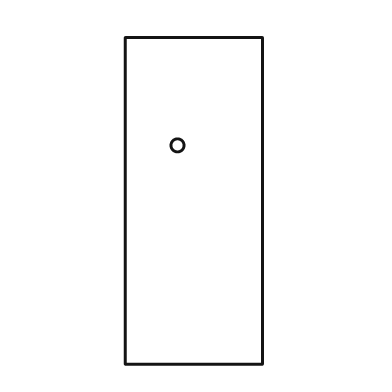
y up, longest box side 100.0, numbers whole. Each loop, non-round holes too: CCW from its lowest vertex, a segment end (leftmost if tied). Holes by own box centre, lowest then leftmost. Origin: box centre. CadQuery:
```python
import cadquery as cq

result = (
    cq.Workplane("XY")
    .moveTo(-21.0, -50.0)
    .lineTo(21.0, -50.0)
    .lineTo(21.0, 50.0)
    .lineTo(-21.0, 50.0)
    .close()
    .moveTo(-5.0, 17.0)
    .circle(2.0)
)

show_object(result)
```